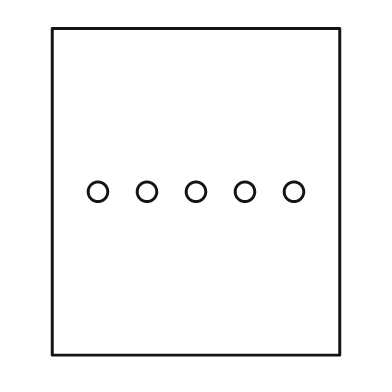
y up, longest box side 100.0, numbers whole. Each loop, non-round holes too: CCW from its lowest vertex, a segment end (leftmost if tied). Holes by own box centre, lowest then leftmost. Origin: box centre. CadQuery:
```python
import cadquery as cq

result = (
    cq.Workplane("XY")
    .moveTo(-44.0, -50.0)
    .lineTo(44.0, -50.0)
    .lineTo(44.0, 50.0)
    .lineTo(-44.0, 50.0)
    .close()
    .moveTo(-30.0, 0.0)
    .circle(3.0)
    .moveTo(-15.0, 0.0)
    .circle(3.0)
    .moveTo(0.0, 0.0)
    .circle(3.0)
    .moveTo(15.0, 0.0)
    .circle(3.0)
    .moveTo(30.0, 0.0)
    .circle(3.0)
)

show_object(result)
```